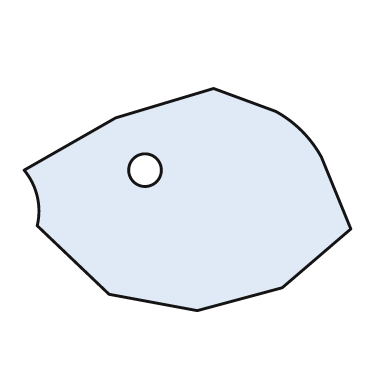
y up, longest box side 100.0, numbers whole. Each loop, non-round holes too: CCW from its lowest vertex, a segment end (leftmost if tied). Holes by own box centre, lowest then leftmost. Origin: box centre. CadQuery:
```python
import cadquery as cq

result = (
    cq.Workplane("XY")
    .moveTo(3.0, -34.0)
    .lineTo(29.0, -27.0)
    .lineTo(50.0, -9.0)
    .lineTo(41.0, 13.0)
    .threePointArc((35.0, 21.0), (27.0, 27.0))
    .lineTo(8.0, 34.0)
    .lineTo(-22.0, 25.0)
    .lineTo(-50.0, 9.0)
    .threePointArc((-46.0, 1.0), (-46.0, -8.0))
    .lineTo(-24.0, -29.0)
    .close()
    .moveTo(-13.0, 9.0)
    .circle(5.0)
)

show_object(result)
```